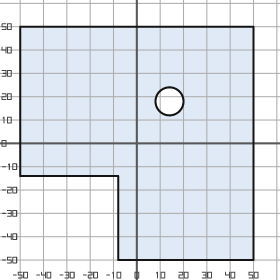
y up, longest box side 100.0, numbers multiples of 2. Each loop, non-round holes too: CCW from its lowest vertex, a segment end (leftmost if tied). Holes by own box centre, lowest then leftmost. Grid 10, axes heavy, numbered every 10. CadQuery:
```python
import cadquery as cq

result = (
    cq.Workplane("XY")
    .moveTo(-8.0, -50.0)
    .lineTo(50.0, -50.0)
    .lineTo(50.0, 50.0)
    .lineTo(-50.0, 50.0)
    .lineTo(-50.0, -14.0)
    .lineTo(-8.0, -14.0)
    .close()
    .moveTo(14.0, 18.0)
    .circle(6.0)
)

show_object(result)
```